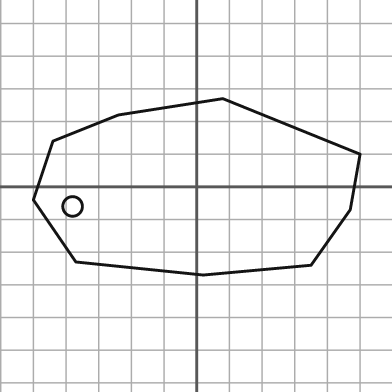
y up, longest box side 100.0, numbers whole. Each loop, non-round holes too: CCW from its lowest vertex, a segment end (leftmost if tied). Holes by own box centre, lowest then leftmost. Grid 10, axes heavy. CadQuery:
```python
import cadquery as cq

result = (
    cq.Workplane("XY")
    .moveTo(2.0, -27.0)
    .lineTo(35.0, -24.0)
    .lineTo(47.0, -7.0)
    .lineTo(50.0, 10.0)
    .lineTo(8.0, 27.0)
    .lineTo(-24.0, 22.0)
    .lineTo(-44.0, 14.0)
    .lineTo(-50.0, -4.0)
    .lineTo(-37.0, -23.0)
    .close()
    .moveTo(-38.0, -6.0)
    .circle(3.0)
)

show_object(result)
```